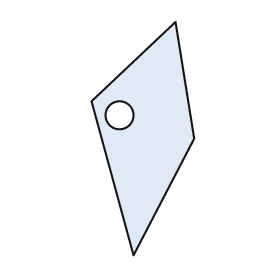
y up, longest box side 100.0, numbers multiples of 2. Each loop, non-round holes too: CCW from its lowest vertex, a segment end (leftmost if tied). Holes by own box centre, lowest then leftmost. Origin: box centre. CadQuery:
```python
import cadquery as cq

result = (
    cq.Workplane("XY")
    .moveTo(-4.0, -50.0)
    .lineTo(22.0, 0.0)
    .lineTo(14.0, 50.0)
    .lineTo(-22.0, 16.0)
    .close()
    .moveTo(-10.0, 10.0)
    .circle(6.0)
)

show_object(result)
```